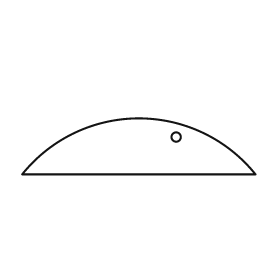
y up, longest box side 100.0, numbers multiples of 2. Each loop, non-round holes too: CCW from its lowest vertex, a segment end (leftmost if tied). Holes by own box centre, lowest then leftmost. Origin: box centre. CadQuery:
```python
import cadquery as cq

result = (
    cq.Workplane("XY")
    .moveTo(-50.0, -12.0)
    .lineTo(50.0, -12.0)
    .threePointArc((0.0, 12.0), (-50.0, -12.0))
    .close()
    .moveTo(16.0, 4.0)
    .circle(2.0)
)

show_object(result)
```